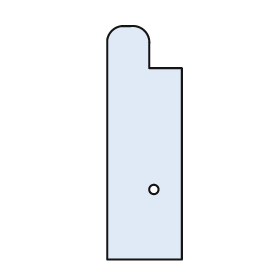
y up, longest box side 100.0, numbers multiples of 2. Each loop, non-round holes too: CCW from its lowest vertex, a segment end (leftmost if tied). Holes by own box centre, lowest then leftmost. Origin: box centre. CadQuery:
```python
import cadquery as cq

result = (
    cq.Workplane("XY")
    .moveTo(-16.0, -50.0)
    .lineTo(16.0, -50.0)
    .lineTo(16.0, 32.0)
    .lineTo(2.0, 32.0)
    .lineTo(2.0, 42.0)
    .threePointArc((0.0, 48.0), (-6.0, 50.0))
    .lineTo(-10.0, 50.0)
    .threePointArc((-14.0, 48.0), (-16.0, 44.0))
    .close()
    .moveTo(4.0, -20.0)
    .circle(2.0)
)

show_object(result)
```